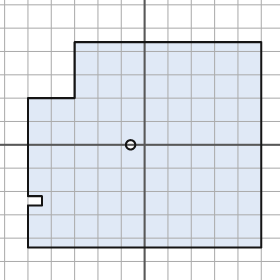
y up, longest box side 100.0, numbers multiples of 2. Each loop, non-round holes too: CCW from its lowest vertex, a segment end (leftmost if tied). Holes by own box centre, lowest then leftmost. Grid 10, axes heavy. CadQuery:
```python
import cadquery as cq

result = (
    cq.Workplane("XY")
    .moveTo(-50.0, -44.0)
    .lineTo(50.0, -44.0)
    .lineTo(50.0, 44.0)
    .lineTo(-30.0, 44.0)
    .lineTo(-30.0, 20.0)
    .lineTo(-50.0, 20.0)
    .lineTo(-50.0, -22.0)
    .lineTo(-44.0, -22.0)
    .lineTo(-44.0, -26.0)
    .lineTo(-50.0, -26.0)
    .close()
    .moveTo(-6.0, 0.0)
    .circle(2.0)
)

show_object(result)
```